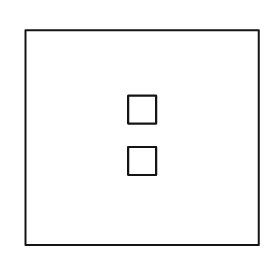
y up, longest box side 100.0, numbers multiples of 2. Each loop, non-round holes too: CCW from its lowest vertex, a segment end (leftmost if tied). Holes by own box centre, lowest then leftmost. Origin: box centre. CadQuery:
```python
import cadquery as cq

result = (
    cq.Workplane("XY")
    .moveTo(-50.0, -46.0)
    .lineTo(50.0, -46.0)
    .lineTo(50.0, 46.0)
    .lineTo(-50.0, 46.0)
    .close()
    .moveTo(-6.0, -16.0)
    .lineTo(6.0, -16.0)
    .lineTo(6.0, -4.0)
    .lineTo(-6.0, -4.0)
    .close()
    .moveTo(-6.0, 6.0)
    .lineTo(6.0, 6.0)
    .lineTo(6.0, 18.0)
    .lineTo(-6.0, 18.0)
    .close()
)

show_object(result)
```